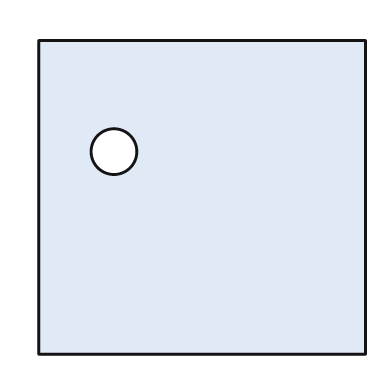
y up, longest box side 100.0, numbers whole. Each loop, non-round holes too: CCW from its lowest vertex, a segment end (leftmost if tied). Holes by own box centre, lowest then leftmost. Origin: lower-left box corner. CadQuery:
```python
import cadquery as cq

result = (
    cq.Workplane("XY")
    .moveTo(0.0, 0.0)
    .lineTo(100.0, 0.0)
    .lineTo(100.0, 96.0)
    .lineTo(0.0, 96.0)
    .close()
    .moveTo(23.0, 62.0)
    .circle(7.0)
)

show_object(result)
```